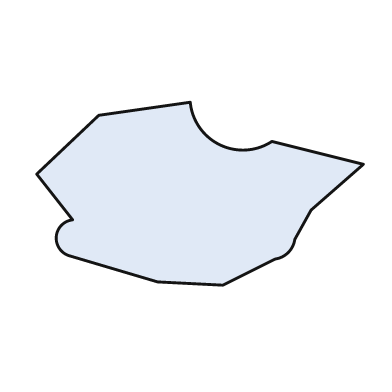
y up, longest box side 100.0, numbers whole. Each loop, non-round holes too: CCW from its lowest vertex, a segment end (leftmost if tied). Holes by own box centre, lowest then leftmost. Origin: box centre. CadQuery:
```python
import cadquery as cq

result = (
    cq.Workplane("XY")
    .moveTo(7.0, -28.0)
    .lineTo(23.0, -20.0)
    .threePointArc((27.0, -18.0), (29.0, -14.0))
    .lineTo(34.0, -5.0)
    .lineTo(50.0, 9.0)
    .lineTo(22.0, 16.0)
    .threePointArc((6.0, 15.0), (-3.0, 28.0))
    .lineTo(-31.0, 24.0)
    .lineTo(-50.0, 6.0)
    .lineTo(-39.0, -8.0)
    .threePointArc((-44.0, -13.0), (-40.0, -19.0))
    .lineTo(-13.0, -27.0)
    .close()
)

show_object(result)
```